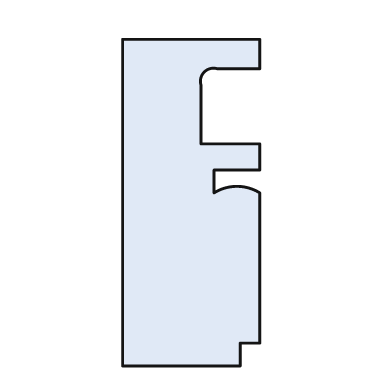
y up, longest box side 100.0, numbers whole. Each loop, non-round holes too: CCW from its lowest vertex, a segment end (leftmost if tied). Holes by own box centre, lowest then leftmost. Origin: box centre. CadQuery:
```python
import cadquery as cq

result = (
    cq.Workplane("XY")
    .moveTo(-21.0, -50.0)
    .lineTo(15.0, -50.0)
    .lineTo(15.0, -43.0)
    .lineTo(21.0, -43.0)
    .lineTo(21.0, 3.0)
    .threePointArc((14.0, 5.0), (7.0, 3.0))
    .lineTo(7.0, 10.0)
    .lineTo(21.0, 10.0)
    .lineTo(21.0, 18.0)
    .lineTo(3.0, 18.0)
    .lineTo(3.0, 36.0)
    .threePointArc((4.0, 40.0), (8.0, 41.0))
    .lineTo(21.0, 41.0)
    .lineTo(21.0, 50.0)
    .lineTo(-21.0, 50.0)
    .close()
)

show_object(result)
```